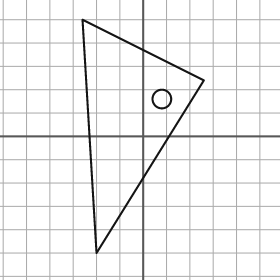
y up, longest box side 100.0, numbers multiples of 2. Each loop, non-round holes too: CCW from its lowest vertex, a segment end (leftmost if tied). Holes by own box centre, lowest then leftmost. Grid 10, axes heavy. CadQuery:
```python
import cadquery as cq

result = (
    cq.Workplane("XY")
    .moveTo(-20.0, -50.0)
    .lineTo(26.0, 24.0)
    .lineTo(-26.0, 50.0)
    .close()
    .moveTo(8.0, 16.0)
    .circle(4.0)
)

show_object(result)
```